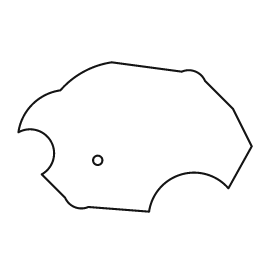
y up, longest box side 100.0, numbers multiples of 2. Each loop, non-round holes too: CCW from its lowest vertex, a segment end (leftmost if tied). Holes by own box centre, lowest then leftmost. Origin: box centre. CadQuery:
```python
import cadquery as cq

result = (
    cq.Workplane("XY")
    .moveTo(6.0, -32.0)
    .threePointArc((20.0, -16.0), (40.0, -22.0))
    .lineTo(50.0, -4.0)
    .lineTo(42.0, 12.0)
    .lineTo(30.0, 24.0)
    .threePointArc((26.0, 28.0), (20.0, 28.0))
    .lineTo(-10.0, 32.0)
    .threePointArc((-22.0, 28.0), (-32.0, 20.0))
    .threePointArc((-44.0, 14.0), (-50.0, 2.0))
    .threePointArc((-36.0, -2.0), (-40.0, -16.0))
    .lineTo(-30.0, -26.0)
    .threePointArc((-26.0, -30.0), (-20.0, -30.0))
    .close()
    .moveTo(-16.0, -10.0)
    .circle(2.0)
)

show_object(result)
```